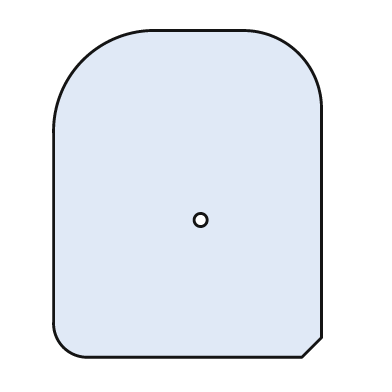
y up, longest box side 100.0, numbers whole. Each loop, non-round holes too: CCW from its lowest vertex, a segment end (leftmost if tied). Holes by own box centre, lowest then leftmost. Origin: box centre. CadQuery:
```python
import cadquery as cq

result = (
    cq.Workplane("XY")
    .moveTo(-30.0, -50.0)
    .lineTo(35.0, -50.0)
    .lineTo(41.0, -44.0)
    .lineTo(41.0, 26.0)
    .threePointArc((34.0, 43.0), (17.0, 50.0))
    .lineTo(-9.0, 50.0)
    .threePointArc((-32.0, 41.0), (-41.0, 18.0))
    .lineTo(-41.0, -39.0)
    .threePointArc((-38.0, -47.0), (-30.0, -50.0))
    .close()
    .moveTo(4.0, -8.0)
    .circle(2.0)
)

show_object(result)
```